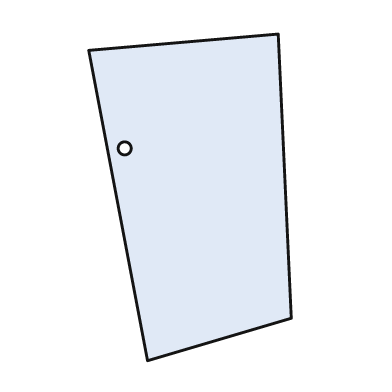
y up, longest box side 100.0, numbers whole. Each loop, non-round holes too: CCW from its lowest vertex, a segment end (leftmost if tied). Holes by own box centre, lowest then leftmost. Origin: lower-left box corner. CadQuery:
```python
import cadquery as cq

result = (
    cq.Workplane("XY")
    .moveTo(18.0, 0.0)
    .lineTo(62.0, 13.0)
    .lineTo(58.0, 100.0)
    .lineTo(0.0, 95.0)
    .close()
    .moveTo(11.0, 65.0)
    .circle(2.0)
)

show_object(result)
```